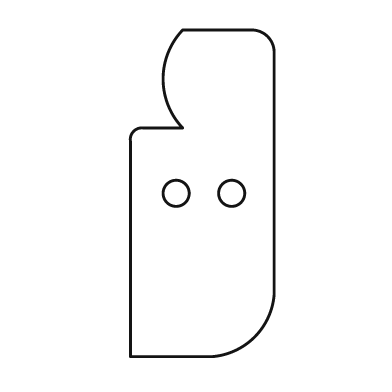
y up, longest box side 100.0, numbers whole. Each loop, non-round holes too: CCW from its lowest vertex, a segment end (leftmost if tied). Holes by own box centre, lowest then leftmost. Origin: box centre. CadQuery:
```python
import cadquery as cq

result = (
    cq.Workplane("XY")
    .moveTo(-22.0, -50.0)
    .lineTo(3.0, -50.0)
    .threePointArc((16.0, -44.0), (22.0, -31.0))
    .lineTo(22.0, 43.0)
    .threePointArc((20.0, 48.0), (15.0, 50.0))
    .lineTo(-6.0, 50.0)
    .threePointArc((-12.0, 35.0), (-6.0, 20.0))
    .lineTo(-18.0, 20.0)
    .threePointArc((-21.0, 19.0), (-22.0, 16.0))
    .close()
    .moveTo(-8.0, 0.0)
    .circle(4.0)
    .moveTo(9.0, 0.0)
    .circle(4.0)
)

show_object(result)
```